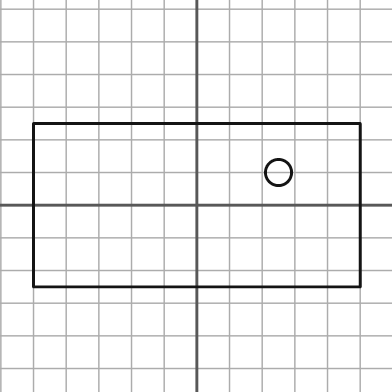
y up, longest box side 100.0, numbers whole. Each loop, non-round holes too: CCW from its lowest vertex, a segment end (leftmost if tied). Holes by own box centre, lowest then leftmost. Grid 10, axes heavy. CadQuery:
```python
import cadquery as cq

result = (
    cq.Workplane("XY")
    .moveTo(-50.0, -25.0)
    .lineTo(50.0, -25.0)
    .lineTo(50.0, 25.0)
    .lineTo(-50.0, 25.0)
    .close()
    .moveTo(25.0, 10.0)
    .circle(4.0)
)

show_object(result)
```